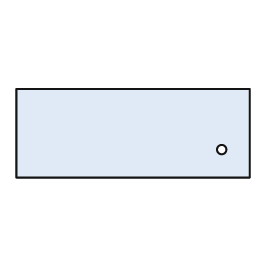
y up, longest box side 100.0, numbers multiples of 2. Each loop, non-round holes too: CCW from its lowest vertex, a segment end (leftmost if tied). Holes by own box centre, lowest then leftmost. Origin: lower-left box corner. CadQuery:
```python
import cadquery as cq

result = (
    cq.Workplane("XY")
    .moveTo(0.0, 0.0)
    .lineTo(100.0, 0.0)
    .lineTo(100.0, 38.0)
    .lineTo(0.0, 38.0)
    .close()
    .moveTo(88.0, 12.0)
    .circle(2.0)
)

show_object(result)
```